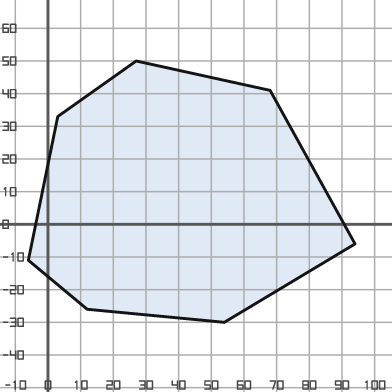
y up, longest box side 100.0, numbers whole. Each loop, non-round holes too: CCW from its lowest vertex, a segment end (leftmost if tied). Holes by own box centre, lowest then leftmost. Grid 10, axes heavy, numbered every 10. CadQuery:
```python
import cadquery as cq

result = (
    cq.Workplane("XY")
    .moveTo(54.0, -30.0)
    .lineTo(94.0, -6.0)
    .lineTo(68.0, 41.0)
    .lineTo(27.0, 50.0)
    .lineTo(3.0, 33.0)
    .lineTo(-6.0, -11.0)
    .lineTo(12.0, -26.0)
    .close()
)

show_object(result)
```